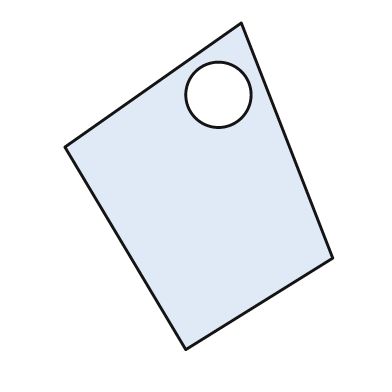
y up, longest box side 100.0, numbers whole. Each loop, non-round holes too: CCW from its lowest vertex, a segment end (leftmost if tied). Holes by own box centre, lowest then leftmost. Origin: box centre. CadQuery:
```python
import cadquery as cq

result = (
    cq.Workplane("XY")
    .moveTo(-4.0, -50.0)
    .lineTo(41.0, -22.0)
    .lineTo(13.0, 50.0)
    .lineTo(-41.0, 12.0)
    .close()
    .moveTo(6.0, 28.0)
    .circle(10.0)
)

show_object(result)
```